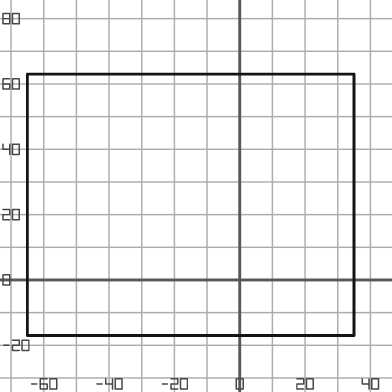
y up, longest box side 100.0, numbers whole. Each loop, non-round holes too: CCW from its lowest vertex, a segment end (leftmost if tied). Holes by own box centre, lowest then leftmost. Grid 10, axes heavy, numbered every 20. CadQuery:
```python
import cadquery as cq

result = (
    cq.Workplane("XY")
    .moveTo(-65.0, -17.0)
    .lineTo(35.0, -17.0)
    .lineTo(35.0, 63.0)
    .lineTo(-65.0, 63.0)
    .close()
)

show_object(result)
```